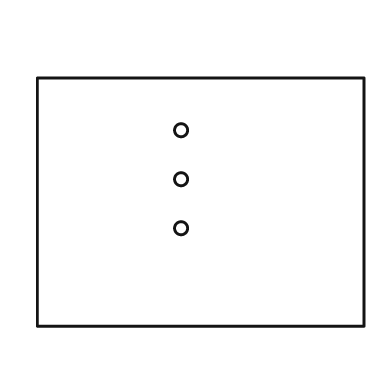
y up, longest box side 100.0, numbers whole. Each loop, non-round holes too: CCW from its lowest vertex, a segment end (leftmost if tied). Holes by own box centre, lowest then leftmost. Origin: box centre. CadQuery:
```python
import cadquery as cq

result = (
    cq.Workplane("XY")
    .moveTo(-50.0, -38.0)
    .lineTo(50.0, -38.0)
    .lineTo(50.0, 38.0)
    .lineTo(-50.0, 38.0)
    .close()
    .moveTo(-6.0, -8.0)
    .circle(2.0)
    .moveTo(-6.0, 7.0)
    .circle(2.0)
    .moveTo(-6.0, 22.0)
    .circle(2.0)
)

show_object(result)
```